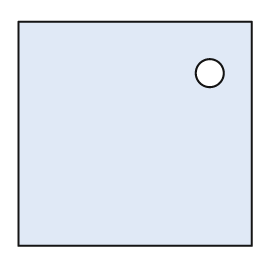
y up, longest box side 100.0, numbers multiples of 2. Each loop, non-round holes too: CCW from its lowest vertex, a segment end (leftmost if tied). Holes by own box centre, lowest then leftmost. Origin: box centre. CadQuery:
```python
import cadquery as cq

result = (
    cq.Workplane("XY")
    .moveTo(-50.0, -48.0)
    .lineTo(50.0, -48.0)
    .lineTo(50.0, 48.0)
    .lineTo(-50.0, 48.0)
    .close()
    .moveTo(32.0, 26.0)
    .circle(6.0)
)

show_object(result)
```